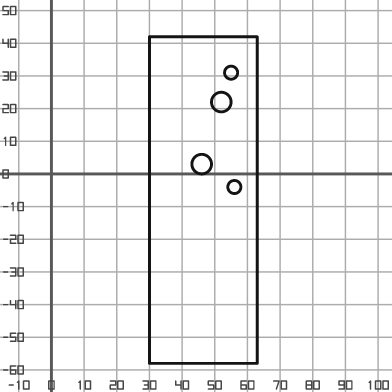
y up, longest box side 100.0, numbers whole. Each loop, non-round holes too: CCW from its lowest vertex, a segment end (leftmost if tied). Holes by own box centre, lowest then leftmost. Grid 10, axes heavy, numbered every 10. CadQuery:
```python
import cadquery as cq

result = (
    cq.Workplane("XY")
    .moveTo(30.0, -58.0)
    .lineTo(63.0, -58.0)
    .lineTo(63.0, 42.0)
    .lineTo(30.0, 42.0)
    .close()
    .moveTo(56.0, -4.0)
    .circle(2.0)
    .moveTo(46.0, 3.0)
    .circle(3.0)
    .moveTo(52.0, 22.0)
    .circle(3.0)
    .moveTo(55.0, 31.0)
    .circle(2.0)
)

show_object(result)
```